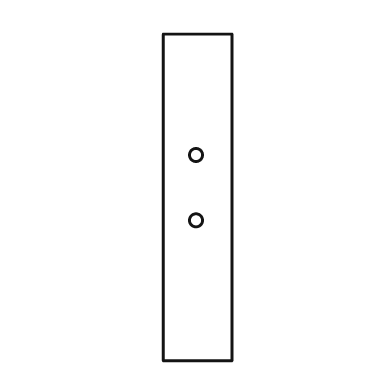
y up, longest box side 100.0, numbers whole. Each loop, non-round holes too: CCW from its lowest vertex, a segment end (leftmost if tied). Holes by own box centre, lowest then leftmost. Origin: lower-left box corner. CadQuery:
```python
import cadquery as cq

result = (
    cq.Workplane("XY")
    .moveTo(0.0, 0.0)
    .lineTo(21.0, 0.0)
    .lineTo(21.0, 100.0)
    .lineTo(0.0, 100.0)
    .close()
    .moveTo(10.0, 43.0)
    .circle(2.0)
    .moveTo(10.0, 63.0)
    .circle(2.0)
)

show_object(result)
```